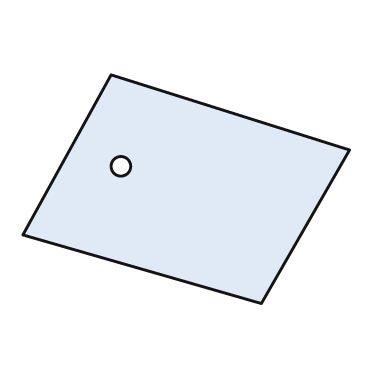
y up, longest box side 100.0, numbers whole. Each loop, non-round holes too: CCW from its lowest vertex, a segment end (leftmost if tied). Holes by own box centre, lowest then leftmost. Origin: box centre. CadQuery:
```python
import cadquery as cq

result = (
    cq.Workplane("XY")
    .moveTo(23.0, -35.0)
    .lineTo(50.0, 12.0)
    .lineTo(-23.0, 35.0)
    .lineTo(-50.0, -14.0)
    .close()
    .moveTo(-20.0, 7.0)
    .circle(3.0)
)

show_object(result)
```